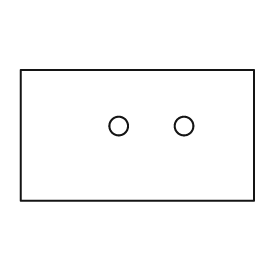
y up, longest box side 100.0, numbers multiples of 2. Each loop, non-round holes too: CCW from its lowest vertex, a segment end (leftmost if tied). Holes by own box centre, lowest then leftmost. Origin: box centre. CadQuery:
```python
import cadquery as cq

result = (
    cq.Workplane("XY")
    .moveTo(-50.0, -28.0)
    .lineTo(50.0, -28.0)
    .lineTo(50.0, 28.0)
    .lineTo(-50.0, 28.0)
    .close()
    .moveTo(-8.0, 4.0)
    .circle(4.0)
    .moveTo(20.0, 4.0)
    .circle(4.0)
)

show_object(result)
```